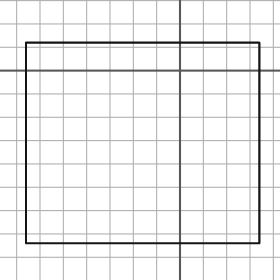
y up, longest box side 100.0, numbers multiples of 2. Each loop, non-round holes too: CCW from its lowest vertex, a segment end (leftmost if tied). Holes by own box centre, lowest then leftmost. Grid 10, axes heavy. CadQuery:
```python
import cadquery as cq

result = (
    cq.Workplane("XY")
    .moveTo(-66.0, -74.0)
    .lineTo(34.0, -74.0)
    .lineTo(34.0, 12.0)
    .lineTo(-66.0, 12.0)
    .close()
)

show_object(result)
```